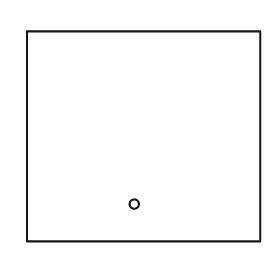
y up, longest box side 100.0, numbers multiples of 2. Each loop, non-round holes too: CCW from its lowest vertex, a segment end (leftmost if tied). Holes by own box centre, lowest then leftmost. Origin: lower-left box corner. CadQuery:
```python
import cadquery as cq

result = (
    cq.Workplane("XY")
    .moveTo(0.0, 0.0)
    .lineTo(100.0, 0.0)
    .lineTo(100.0, 90.0)
    .lineTo(0.0, 90.0)
    .close()
    .moveTo(46.0, 16.0)
    .circle(2.0)
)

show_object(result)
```